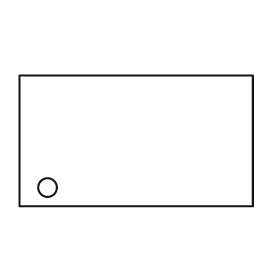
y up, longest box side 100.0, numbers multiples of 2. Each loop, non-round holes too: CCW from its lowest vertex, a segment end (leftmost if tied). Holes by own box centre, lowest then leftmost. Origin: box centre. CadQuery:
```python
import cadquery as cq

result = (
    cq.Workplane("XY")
    .moveTo(-50.0, -28.0)
    .lineTo(50.0, -28.0)
    .lineTo(50.0, 28.0)
    .lineTo(-50.0, 28.0)
    .close()
    .moveTo(-38.0, -20.0)
    .circle(4.0)
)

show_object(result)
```